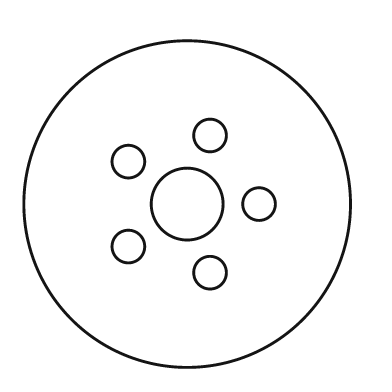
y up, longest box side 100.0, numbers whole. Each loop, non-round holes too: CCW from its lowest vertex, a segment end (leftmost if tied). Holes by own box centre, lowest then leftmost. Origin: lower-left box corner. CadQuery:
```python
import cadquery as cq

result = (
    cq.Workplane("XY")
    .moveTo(50.0, 50.0)
    .circle(50.0)
    .moveTo(57.0, 29.0)
    .circle(5.0)
    .moveTo(32.0, 37.0)
    .circle(5.0)
    .moveTo(50.0, 50.0)
    .circle(11.0)
    .moveTo(72.0, 50.0)
    .circle(5.0)
    .moveTo(32.0, 63.0)
    .circle(5.0)
    .moveTo(57.0, 71.0)
    .circle(5.0)
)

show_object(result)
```